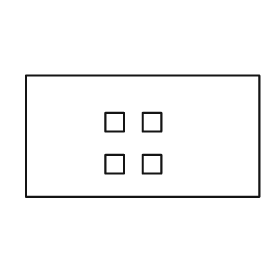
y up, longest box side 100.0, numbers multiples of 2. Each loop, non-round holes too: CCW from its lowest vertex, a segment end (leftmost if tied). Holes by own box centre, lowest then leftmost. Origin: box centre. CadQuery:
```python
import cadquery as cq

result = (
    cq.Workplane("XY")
    .moveTo(-50.0, -26.0)
    .lineTo(50.0, -26.0)
    .lineTo(50.0, 26.0)
    .lineTo(-50.0, 26.0)
    .close()
    .moveTo(-16.0, -16.0)
    .lineTo(-8.0, -16.0)
    .lineTo(-8.0, -8.0)
    .lineTo(-16.0, -8.0)
    .close()
    .moveTo(0.0, -16.0)
    .lineTo(8.0, -16.0)
    .lineTo(8.0, -8.0)
    .lineTo(0.0, -8.0)
    .close()
    .moveTo(-16.0, 2.0)
    .lineTo(-8.0, 2.0)
    .lineTo(-8.0, 10.0)
    .lineTo(-16.0, 10.0)
    .close()
    .moveTo(0.0, 2.0)
    .lineTo(8.0, 2.0)
    .lineTo(8.0, 10.0)
    .lineTo(0.0, 10.0)
    .close()
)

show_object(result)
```